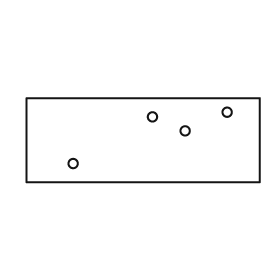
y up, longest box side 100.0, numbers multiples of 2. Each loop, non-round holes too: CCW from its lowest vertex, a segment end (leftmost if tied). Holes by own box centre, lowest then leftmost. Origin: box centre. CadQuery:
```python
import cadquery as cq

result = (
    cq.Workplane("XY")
    .moveTo(-50.0, -18.0)
    .lineTo(50.0, -18.0)
    .lineTo(50.0, 18.0)
    .lineTo(-50.0, 18.0)
    .close()
    .moveTo(-30.0, -10.0)
    .circle(2.0)
    .moveTo(18.0, 4.0)
    .circle(2.0)
    .moveTo(4.0, 10.0)
    .circle(2.0)
    .moveTo(36.0, 12.0)
    .circle(2.0)
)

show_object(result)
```